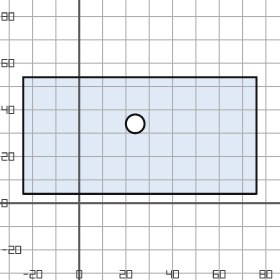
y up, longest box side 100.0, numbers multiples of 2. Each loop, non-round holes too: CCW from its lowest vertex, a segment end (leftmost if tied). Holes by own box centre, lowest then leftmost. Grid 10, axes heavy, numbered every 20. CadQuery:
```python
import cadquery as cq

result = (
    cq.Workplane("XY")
    .moveTo(-24.0, 4.0)
    .lineTo(76.0, 4.0)
    .lineTo(76.0, 54.0)
    .lineTo(-24.0, 54.0)
    .close()
    .moveTo(24.0, 34.0)
    .circle(4.0)
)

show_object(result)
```